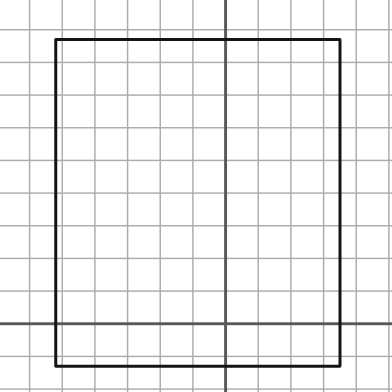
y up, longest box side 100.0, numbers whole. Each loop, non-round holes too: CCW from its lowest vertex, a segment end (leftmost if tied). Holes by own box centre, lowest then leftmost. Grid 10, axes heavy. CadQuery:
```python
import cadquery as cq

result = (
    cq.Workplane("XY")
    .moveTo(-52.0, -13.0)
    .lineTo(35.0, -13.0)
    .lineTo(35.0, 87.0)
    .lineTo(-52.0, 87.0)
    .close()
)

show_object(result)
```